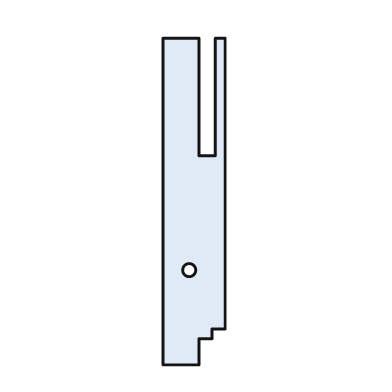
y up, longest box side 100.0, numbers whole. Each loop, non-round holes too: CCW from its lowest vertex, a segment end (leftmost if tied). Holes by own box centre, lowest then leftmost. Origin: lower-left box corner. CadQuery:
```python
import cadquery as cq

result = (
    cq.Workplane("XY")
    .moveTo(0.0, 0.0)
    .lineTo(11.0, 0.0)
    .lineTo(11.0, 8.0)
    .lineTo(15.0, 8.0)
    .lineTo(15.0, 11.0)
    .lineTo(19.0, 11.0)
    .lineTo(19.0, 100.0)
    .lineTo(16.0, 100.0)
    .lineTo(16.0, 64.0)
    .lineTo(11.0, 64.0)
    .lineTo(11.0, 100.0)
    .lineTo(0.0, 100.0)
    .close()
    .moveTo(8.0, 29.0)
    .circle(2.0)
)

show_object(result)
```